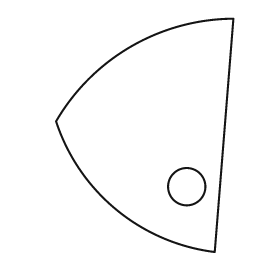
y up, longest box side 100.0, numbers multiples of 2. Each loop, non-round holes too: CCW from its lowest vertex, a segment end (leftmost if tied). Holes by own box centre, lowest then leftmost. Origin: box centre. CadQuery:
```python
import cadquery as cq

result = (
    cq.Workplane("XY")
    .moveTo(30.0, -50.0)
    .lineTo(38.0, 50.0)
    .threePointArc((-6.0, 38.0), (-38.0, 6.0))
    .threePointArc((-12.0, -32.0), (30.0, -50.0))
    .close()
    .moveTo(18.0, -22.0)
    .circle(8.0)
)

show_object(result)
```